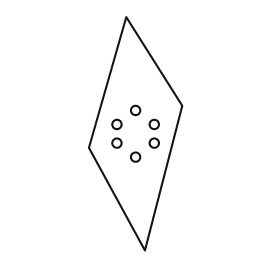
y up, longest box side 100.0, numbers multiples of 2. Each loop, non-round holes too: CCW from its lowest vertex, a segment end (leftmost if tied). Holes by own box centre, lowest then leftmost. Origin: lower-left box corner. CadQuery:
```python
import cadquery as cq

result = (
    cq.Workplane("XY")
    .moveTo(24.0, 0.0)
    .lineTo(40.0, 62.0)
    .lineTo(16.0, 100.0)
    .lineTo(0.0, 44.0)
    .close()
    .moveTo(20.0, 40.0)
    .circle(2.0)
    .moveTo(12.0, 46.0)
    .circle(2.0)
    .moveTo(28.0, 46.0)
    .circle(2.0)
    .moveTo(12.0, 54.0)
    .circle(2.0)
    .moveTo(28.0, 54.0)
    .circle(2.0)
    .moveTo(20.0, 60.0)
    .circle(2.0)
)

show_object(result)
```